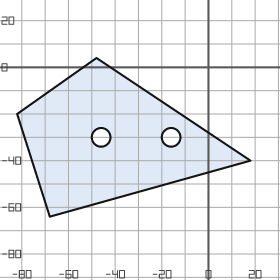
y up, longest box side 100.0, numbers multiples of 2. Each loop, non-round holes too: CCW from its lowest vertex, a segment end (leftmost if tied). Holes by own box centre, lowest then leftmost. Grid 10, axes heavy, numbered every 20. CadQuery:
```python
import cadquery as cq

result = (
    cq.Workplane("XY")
    .moveTo(-68.0, -64.0)
    .lineTo(18.0, -40.0)
    .lineTo(-48.0, 4.0)
    .lineTo(-82.0, -20.0)
    .close()
    .moveTo(-46.0, -30.0)
    .circle(4.0)
    .moveTo(-16.0, -30.0)
    .circle(4.0)
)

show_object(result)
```